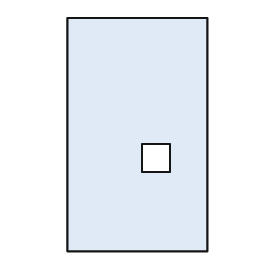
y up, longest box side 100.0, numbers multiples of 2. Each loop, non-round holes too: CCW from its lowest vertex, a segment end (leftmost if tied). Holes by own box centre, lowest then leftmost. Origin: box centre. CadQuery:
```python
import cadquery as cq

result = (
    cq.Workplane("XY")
    .moveTo(-30.0, -50.0)
    .lineTo(30.0, -50.0)
    .lineTo(30.0, 50.0)
    .lineTo(-30.0, 50.0)
    .close()
    .moveTo(2.0, -16.0)
    .lineTo(14.0, -16.0)
    .lineTo(14.0, -4.0)
    .lineTo(2.0, -4.0)
    .close()
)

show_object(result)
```